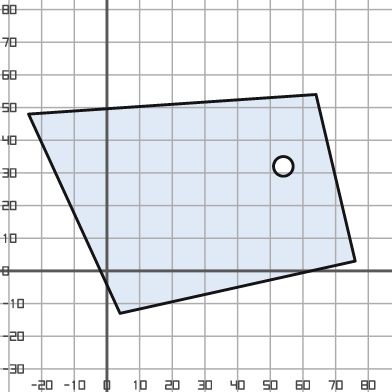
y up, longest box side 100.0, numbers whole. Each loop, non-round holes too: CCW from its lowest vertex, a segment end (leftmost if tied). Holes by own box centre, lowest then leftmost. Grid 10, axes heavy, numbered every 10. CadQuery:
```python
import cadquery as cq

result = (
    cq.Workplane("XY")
    .moveTo(4.0, -13.0)
    .lineTo(76.0, 3.0)
    .lineTo(64.0, 54.0)
    .lineTo(-24.0, 48.0)
    .close()
    .moveTo(54.0, 32.0)
    .circle(3.0)
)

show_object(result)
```